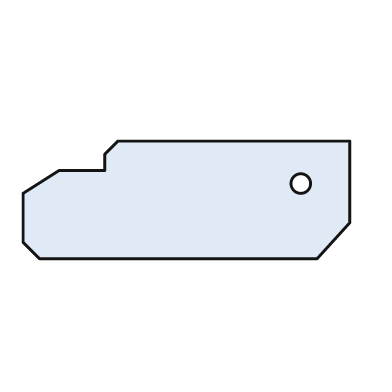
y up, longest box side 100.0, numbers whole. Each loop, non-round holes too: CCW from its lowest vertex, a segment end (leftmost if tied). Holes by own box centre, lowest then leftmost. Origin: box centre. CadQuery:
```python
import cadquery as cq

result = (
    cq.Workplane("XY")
    .moveTo(-45.0, -18.0)
    .lineTo(40.0, -18.0)
    .lineTo(50.0, -7.0)
    .lineTo(50.0, 18.0)
    .lineTo(-21.0, 18.0)
    .lineTo(-25.0, 14.0)
    .lineTo(-25.0, 9.0)
    .lineTo(-39.0, 9.0)
    .lineTo(-50.0, 2.0)
    .lineTo(-50.0, -13.0)
    .close()
    .moveTo(35.0, 5.0)
    .circle(3.0)
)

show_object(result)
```